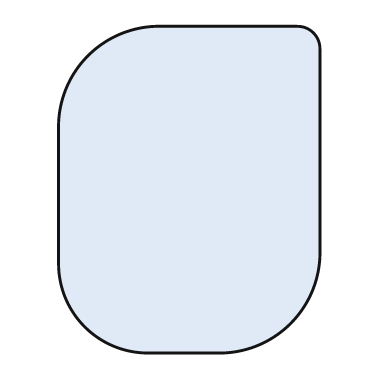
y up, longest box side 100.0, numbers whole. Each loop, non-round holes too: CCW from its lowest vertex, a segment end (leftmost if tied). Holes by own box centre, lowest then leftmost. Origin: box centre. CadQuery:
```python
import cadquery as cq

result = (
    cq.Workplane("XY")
    .moveTo(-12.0, -50.0)
    .lineTo(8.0, -50.0)
    .threePointArc((31.0, -41.0), (40.0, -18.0))
    .lineTo(40.0, 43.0)
    .threePointArc((38.0, 48.0), (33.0, 50.0))
    .lineTo(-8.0, 50.0)
    .threePointArc((-31.0, 41.0), (-40.0, 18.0))
    .lineTo(-40.0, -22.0)
    .threePointArc((-32.0, -42.0), (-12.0, -50.0))
    .close()
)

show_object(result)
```